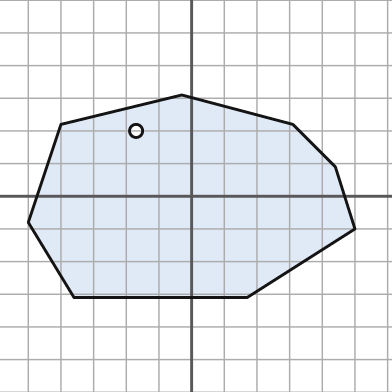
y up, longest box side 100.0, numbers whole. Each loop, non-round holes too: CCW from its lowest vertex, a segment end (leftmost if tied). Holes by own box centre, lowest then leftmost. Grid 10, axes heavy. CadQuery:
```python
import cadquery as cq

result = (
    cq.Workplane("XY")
    .moveTo(-36.0, -31.0)
    .lineTo(17.0, -31.0)
    .lineTo(50.0, -10.0)
    .lineTo(44.0, 9.0)
    .lineTo(31.0, 22.0)
    .lineTo(-3.0, 31.0)
    .lineTo(-40.0, 22.0)
    .lineTo(-50.0, -8.0)
    .close()
    .moveTo(-17.0, 20.0)
    .circle(2.0)
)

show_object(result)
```